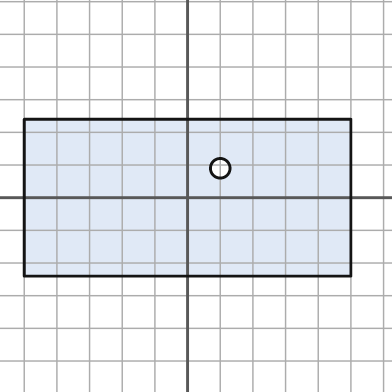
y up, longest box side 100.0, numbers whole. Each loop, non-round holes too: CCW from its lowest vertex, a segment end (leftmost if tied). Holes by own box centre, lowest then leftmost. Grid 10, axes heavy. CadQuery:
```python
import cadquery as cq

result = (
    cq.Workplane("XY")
    .moveTo(-50.0, -24.0)
    .lineTo(50.0, -24.0)
    .lineTo(50.0, 24.0)
    .lineTo(-50.0, 24.0)
    .close()
    .moveTo(10.0, 9.0)
    .circle(3.0)
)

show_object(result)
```